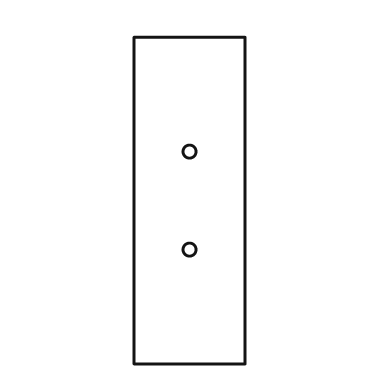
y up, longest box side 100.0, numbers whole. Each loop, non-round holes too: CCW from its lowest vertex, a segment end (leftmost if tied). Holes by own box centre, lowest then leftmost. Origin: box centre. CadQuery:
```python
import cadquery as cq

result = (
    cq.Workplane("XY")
    .moveTo(-17.0, -50.0)
    .lineTo(17.0, -50.0)
    .lineTo(17.0, 50.0)
    .lineTo(-17.0, 50.0)
    .close()
    .moveTo(0.0, -15.0)
    .circle(2.0)
    .moveTo(0.0, 15.0)
    .circle(2.0)
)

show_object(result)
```